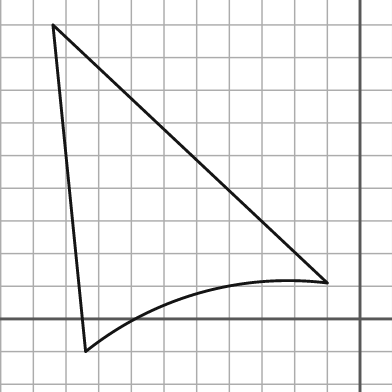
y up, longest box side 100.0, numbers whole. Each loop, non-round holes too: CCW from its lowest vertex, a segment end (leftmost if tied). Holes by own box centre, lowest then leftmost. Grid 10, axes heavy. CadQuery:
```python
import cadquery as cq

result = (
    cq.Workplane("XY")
    .moveTo(-84.0, -10.0)
    .threePointArc((-49.0, 8.0), (-10.0, 11.0))
    .lineTo(-94.0, 90.0)
    .close()
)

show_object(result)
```